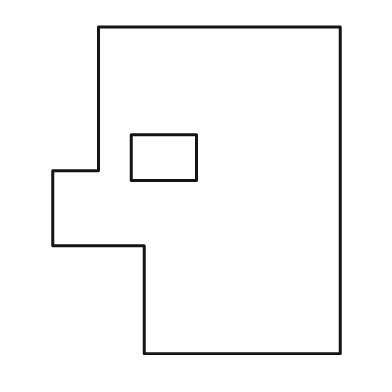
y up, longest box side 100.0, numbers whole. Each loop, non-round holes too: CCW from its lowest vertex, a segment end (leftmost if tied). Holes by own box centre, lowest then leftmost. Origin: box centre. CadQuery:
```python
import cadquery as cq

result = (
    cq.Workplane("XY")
    .moveTo(-16.0, -50.0)
    .lineTo(44.0, -50.0)
    .lineTo(44.0, 50.0)
    .lineTo(-30.0, 50.0)
    .lineTo(-30.0, 6.0)
    .lineTo(-44.0, 6.0)
    .lineTo(-44.0, -17.0)
    .lineTo(-16.0, -17.0)
    .close()
    .moveTo(-20.0, 3.0)
    .lineTo(0.0, 3.0)
    .lineTo(0.0, 17.0)
    .lineTo(-20.0, 17.0)
    .close()
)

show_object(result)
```